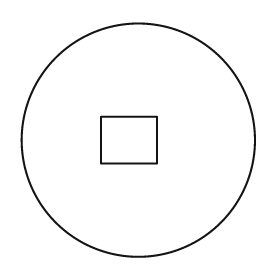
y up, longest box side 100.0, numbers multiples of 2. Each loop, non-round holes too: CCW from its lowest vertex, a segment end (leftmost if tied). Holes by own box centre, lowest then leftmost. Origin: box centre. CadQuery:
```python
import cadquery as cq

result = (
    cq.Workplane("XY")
    .moveTo(0.0, 0.0)
    .circle(50.0)
    .moveTo(-16.0, -10.0)
    .lineTo(8.0, -10.0)
    .lineTo(8.0, 10.0)
    .lineTo(-16.0, 10.0)
    .close()
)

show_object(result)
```